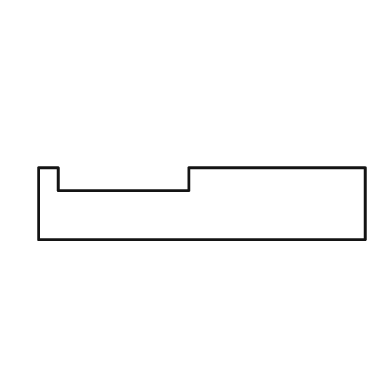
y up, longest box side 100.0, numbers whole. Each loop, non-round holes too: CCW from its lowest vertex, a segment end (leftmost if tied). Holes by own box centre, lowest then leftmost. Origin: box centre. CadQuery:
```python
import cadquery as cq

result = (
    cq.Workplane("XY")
    .moveTo(-50.0, -11.0)
    .lineTo(50.0, -11.0)
    .lineTo(50.0, 11.0)
    .lineTo(-4.0, 11.0)
    .lineTo(-4.0, 4.0)
    .lineTo(-44.0, 4.0)
    .lineTo(-44.0, 11.0)
    .lineTo(-50.0, 11.0)
    .close()
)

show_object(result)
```